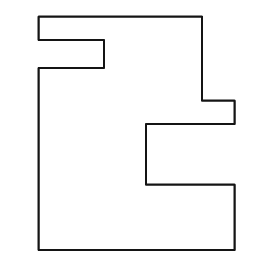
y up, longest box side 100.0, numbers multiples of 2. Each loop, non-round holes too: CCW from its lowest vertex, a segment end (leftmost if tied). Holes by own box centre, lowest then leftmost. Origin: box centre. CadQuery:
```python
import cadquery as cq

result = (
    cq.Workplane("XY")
    .moveTo(-42.0, -50.0)
    .lineTo(42.0, -50.0)
    .lineTo(42.0, -22.0)
    .lineTo(4.0, -22.0)
    .lineTo(4.0, 4.0)
    .lineTo(42.0, 4.0)
    .lineTo(42.0, 14.0)
    .lineTo(28.0, 14.0)
    .lineTo(28.0, 50.0)
    .lineTo(-42.0, 50.0)
    .lineTo(-42.0, 40.0)
    .lineTo(-14.0, 40.0)
    .lineTo(-14.0, 28.0)
    .lineTo(-42.0, 28.0)
    .close()
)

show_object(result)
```